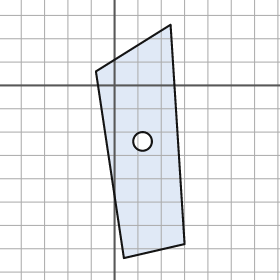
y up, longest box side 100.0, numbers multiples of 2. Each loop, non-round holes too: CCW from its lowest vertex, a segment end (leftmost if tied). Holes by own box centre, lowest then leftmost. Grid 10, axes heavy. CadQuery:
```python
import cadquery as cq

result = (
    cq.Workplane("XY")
    .moveTo(4.0, -74.0)
    .lineTo(30.0, -68.0)
    .lineTo(24.0, 26.0)
    .lineTo(-8.0, 6.0)
    .close()
    .moveTo(12.0, -24.0)
    .circle(4.0)
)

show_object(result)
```